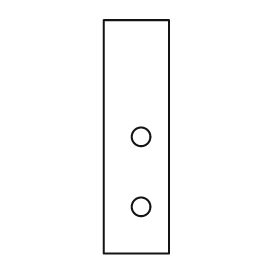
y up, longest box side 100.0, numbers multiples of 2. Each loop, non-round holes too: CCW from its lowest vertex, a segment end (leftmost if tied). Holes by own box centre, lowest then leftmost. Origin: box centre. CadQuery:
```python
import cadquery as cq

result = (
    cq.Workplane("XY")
    .moveTo(-14.0, -50.0)
    .lineTo(14.0, -50.0)
    .lineTo(14.0, 50.0)
    .lineTo(-14.0, 50.0)
    .close()
    .moveTo(2.0, -30.0)
    .circle(4.0)
    .moveTo(2.0, 0.0)
    .circle(4.0)
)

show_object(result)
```